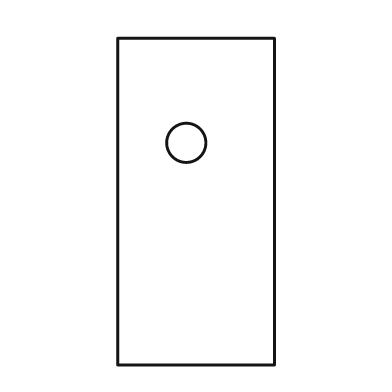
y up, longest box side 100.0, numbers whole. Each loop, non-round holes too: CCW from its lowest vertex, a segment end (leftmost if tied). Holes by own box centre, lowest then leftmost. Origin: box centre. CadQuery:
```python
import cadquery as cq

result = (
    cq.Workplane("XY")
    .moveTo(-24.0, -50.0)
    .lineTo(24.0, -50.0)
    .lineTo(24.0, 50.0)
    .lineTo(-24.0, 50.0)
    .close()
    .moveTo(-3.0, 18.0)
    .circle(6.0)
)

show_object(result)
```